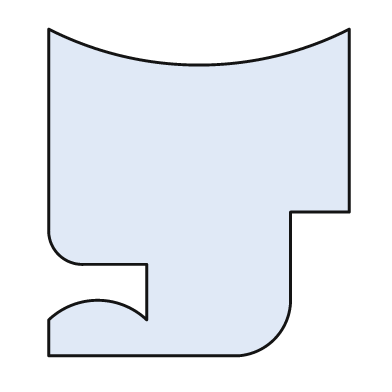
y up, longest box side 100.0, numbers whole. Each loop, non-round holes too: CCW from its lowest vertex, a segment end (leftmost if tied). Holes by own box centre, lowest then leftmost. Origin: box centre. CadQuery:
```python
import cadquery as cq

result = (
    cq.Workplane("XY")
    .moveTo(-46.0, -50.0)
    .lineTo(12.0, -50.0)
    .threePointArc((23.0, -45.0), (28.0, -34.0))
    .lineTo(28.0, -6.0)
    .lineTo(46.0, -6.0)
    .lineTo(46.0, 50.0)
    .threePointArc((0.0, 39.0), (-46.0, 50.0))
    .lineTo(-46.0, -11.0)
    .threePointArc((-43.0, -19.0), (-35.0, -22.0))
    .lineTo(-16.0, -22.0)
    .lineTo(-16.0, -39.0)
    .threePointArc((-31.0, -33.0), (-46.0, -39.0))
    .close()
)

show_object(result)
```